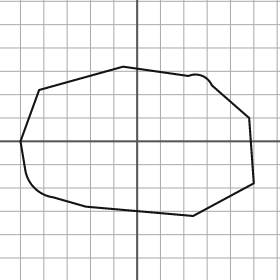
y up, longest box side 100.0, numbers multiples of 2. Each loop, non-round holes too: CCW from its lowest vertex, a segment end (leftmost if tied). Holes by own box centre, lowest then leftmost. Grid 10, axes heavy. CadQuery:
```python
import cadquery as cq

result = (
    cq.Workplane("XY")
    .moveTo(24.0, -32.0)
    .lineTo(50.0, -18.0)
    .lineTo(48.0, 10.0)
    .lineTo(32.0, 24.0)
    .threePointArc((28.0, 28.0), (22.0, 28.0))
    .lineTo(-6.0, 32.0)
    .lineTo(-42.0, 22.0)
    .lineTo(-50.0, 0.0)
    .lineTo(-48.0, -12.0)
    .threePointArc((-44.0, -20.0), (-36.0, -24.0))
    .lineTo(-22.0, -28.0)
    .close()
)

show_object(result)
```